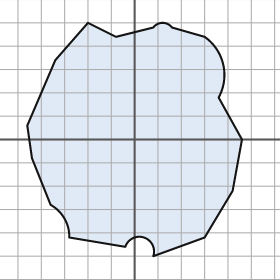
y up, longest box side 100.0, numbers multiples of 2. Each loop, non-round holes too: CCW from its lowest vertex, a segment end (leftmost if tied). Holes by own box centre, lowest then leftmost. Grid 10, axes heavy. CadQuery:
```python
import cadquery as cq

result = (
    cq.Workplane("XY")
    .moveTo(8.0, -50.0)
    .lineTo(30.0, -42.0)
    .lineTo(42.0, -22.0)
    .lineTo(46.0, 0.0)
    .lineTo(36.0, 18.0)
    .threePointArc((38.0, 32.0), (30.0, 44.0))
    .lineTo(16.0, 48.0)
    .threePointArc((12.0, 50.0), (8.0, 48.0))
    .lineTo(-8.0, 44.0)
    .lineTo(-20.0, 50.0)
    .lineTo(-34.0, 34.0)
    .lineTo(-46.0, 6.0)
    .lineTo(-44.0, -8.0)
    .lineTo(-36.0, -28.0)
    .threePointArc((-30.0, -34.0), (-28.0, -42.0))
    .lineTo(-4.0, -46.0)
    .threePointArc((4.0, -42.0), (8.0, -50.0))
    .close()
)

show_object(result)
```